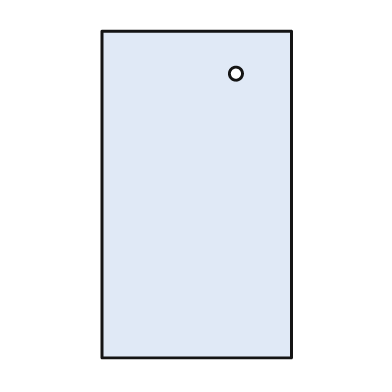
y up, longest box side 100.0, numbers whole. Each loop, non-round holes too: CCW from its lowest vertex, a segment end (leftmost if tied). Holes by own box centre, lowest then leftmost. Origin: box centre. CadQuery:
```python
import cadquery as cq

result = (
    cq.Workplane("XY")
    .moveTo(-29.0, -50.0)
    .lineTo(29.0, -50.0)
    .lineTo(29.0, 50.0)
    .lineTo(-29.0, 50.0)
    .close()
    .moveTo(12.0, 37.0)
    .circle(2.0)
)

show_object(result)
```